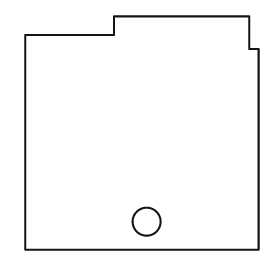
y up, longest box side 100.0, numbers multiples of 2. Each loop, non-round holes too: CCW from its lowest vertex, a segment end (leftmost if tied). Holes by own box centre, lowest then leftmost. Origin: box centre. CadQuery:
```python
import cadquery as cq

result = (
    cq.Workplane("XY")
    .moveTo(-50.0, -50.0)
    .lineTo(50.0, -50.0)
    .lineTo(50.0, 36.0)
    .lineTo(46.0, 36.0)
    .lineTo(46.0, 50.0)
    .lineTo(-12.0, 50.0)
    .lineTo(-12.0, 42.0)
    .lineTo(-50.0, 42.0)
    .close()
    .moveTo(2.0, -38.0)
    .circle(6.0)
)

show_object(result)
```